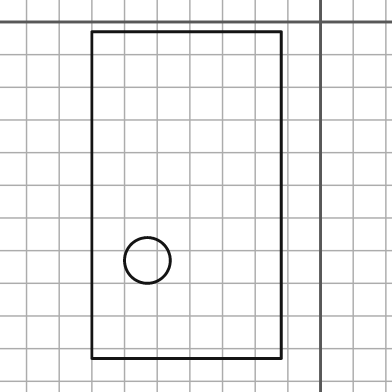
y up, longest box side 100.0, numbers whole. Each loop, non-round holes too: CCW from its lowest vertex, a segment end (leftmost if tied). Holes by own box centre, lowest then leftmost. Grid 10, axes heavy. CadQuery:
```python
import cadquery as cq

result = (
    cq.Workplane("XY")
    .moveTo(-70.0, -103.0)
    .lineTo(-12.0, -103.0)
    .lineTo(-12.0, -3.0)
    .lineTo(-70.0, -3.0)
    .close()
    .moveTo(-53.0, -73.0)
    .circle(7.0)
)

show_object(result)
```